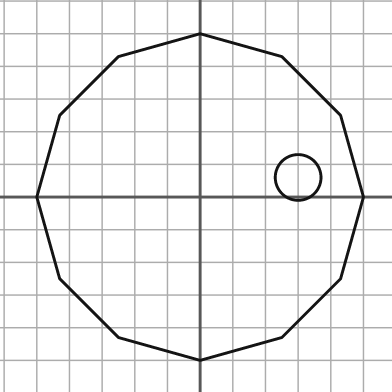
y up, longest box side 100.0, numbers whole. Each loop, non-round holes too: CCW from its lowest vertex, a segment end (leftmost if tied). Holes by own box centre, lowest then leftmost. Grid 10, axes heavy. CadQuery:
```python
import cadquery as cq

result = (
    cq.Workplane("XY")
    .moveTo(0.0, -50.0)
    .lineTo(25.0, -43.0)
    .lineTo(43.0, -25.0)
    .lineTo(50.0, 0.0)
    .lineTo(43.0, 25.0)
    .lineTo(25.0, 43.0)
    .lineTo(0.0, 50.0)
    .lineTo(-25.0, 43.0)
    .lineTo(-43.0, 25.0)
    .lineTo(-50.0, 0.0)
    .lineTo(-43.0, -25.0)
    .lineTo(-25.0, -43.0)
    .close()
    .moveTo(30.0, 6.0)
    .circle(7.0)
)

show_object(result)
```